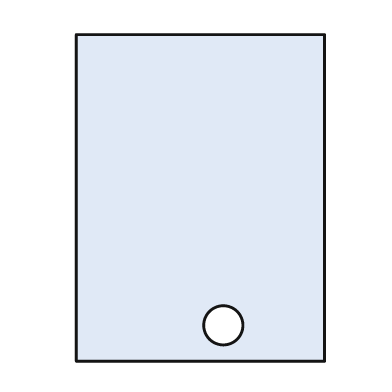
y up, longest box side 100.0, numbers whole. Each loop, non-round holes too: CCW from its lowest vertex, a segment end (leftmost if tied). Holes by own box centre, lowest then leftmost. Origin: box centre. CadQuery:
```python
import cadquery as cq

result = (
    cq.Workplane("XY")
    .moveTo(-38.0, -50.0)
    .lineTo(38.0, -50.0)
    .lineTo(38.0, 50.0)
    .lineTo(-38.0, 50.0)
    .close()
    .moveTo(7.0, -39.0)
    .circle(6.0)
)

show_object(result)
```